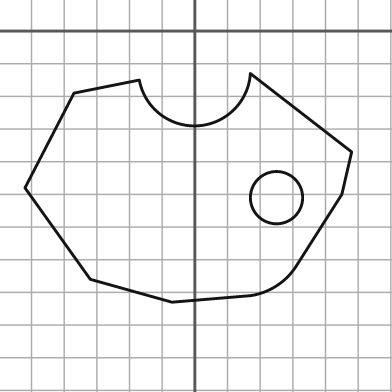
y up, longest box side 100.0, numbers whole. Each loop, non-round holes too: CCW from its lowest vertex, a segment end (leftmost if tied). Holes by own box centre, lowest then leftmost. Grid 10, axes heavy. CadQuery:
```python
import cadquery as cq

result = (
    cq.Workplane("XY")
    .moveTo(-7.0, -83.0)
    .lineTo(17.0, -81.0)
    .threePointArc((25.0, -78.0), (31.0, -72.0))
    .lineTo(45.0, -50.0)
    .lineTo(48.0, -37.0)
    .lineTo(17.0, -13.0)
    .threePointArc((1.0, -29.0), (-17.0, -15.0))
    .lineTo(-37.0, -19.0)
    .lineTo(-52.0, -48.0)
    .lineTo(-32.0, -76.0)
    .close()
    .moveTo(25.0, -51.0)
    .circle(8.0)
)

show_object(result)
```